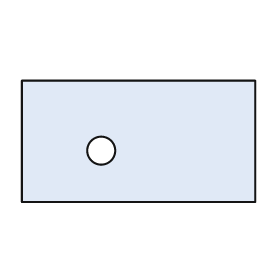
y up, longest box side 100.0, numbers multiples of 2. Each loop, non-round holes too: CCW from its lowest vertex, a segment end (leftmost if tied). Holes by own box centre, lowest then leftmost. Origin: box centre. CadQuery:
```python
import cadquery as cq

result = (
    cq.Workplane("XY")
    .moveTo(-50.0, -26.0)
    .lineTo(50.0, -26.0)
    .lineTo(50.0, 26.0)
    .lineTo(-50.0, 26.0)
    .close()
    .moveTo(-16.0, -4.0)
    .circle(6.0)
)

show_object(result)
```